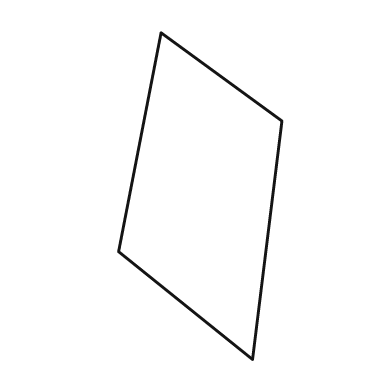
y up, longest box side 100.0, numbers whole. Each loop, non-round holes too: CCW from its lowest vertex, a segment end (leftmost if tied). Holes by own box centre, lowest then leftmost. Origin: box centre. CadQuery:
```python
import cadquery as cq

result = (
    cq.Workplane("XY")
    .moveTo(16.0, -50.0)
    .lineTo(25.0, 23.0)
    .lineTo(-12.0, 50.0)
    .lineTo(-25.0, -17.0)
    .close()
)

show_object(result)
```